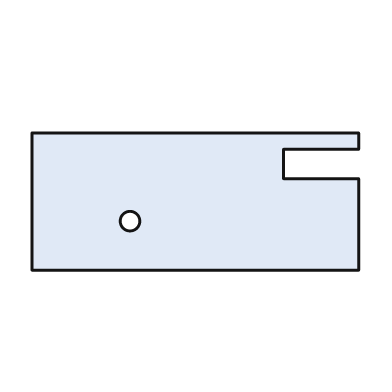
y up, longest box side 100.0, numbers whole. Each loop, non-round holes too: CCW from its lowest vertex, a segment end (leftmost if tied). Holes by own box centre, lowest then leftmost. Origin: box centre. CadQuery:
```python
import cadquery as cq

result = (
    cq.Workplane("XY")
    .moveTo(-50.0, -21.0)
    .lineTo(50.0, -21.0)
    .lineTo(50.0, 7.0)
    .lineTo(27.0, 7.0)
    .lineTo(27.0, 16.0)
    .lineTo(50.0, 16.0)
    .lineTo(50.0, 21.0)
    .lineTo(-50.0, 21.0)
    .close()
    .moveTo(-20.0, -6.0)
    .circle(3.0)
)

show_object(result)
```